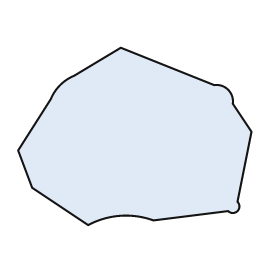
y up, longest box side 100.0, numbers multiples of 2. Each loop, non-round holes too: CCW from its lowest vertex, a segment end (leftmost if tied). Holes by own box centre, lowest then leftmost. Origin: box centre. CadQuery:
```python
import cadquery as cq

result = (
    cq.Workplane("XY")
    .moveTo(-20.0, -38.0)
    .threePointArc((-6.0, -34.0), (8.0, -36.0))
    .lineTo(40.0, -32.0)
    .threePointArc((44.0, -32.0), (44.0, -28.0))
    .lineTo(50.0, 2.0)
    .lineTo(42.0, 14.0)
    .threePointArc((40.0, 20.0), (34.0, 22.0))
    .lineTo(-6.0, 38.0)
    .lineTo(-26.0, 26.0)
    .threePointArc((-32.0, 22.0), (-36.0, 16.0))
    .lineTo(-50.0, -6.0)
    .lineTo(-44.0, -22.0)
    .close()
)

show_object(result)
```